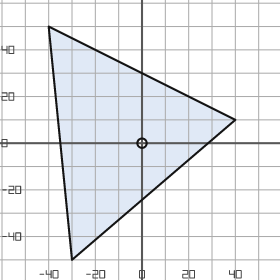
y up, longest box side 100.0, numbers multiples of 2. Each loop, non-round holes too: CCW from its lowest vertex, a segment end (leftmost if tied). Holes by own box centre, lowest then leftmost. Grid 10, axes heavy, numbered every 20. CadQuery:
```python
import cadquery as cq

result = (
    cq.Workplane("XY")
    .moveTo(-30.0, -50.0)
    .lineTo(40.0, 10.0)
    .lineTo(-40.0, 50.0)
    .close()
    .moveTo(0.0, 0.0)
    .circle(2.0)
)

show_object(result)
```